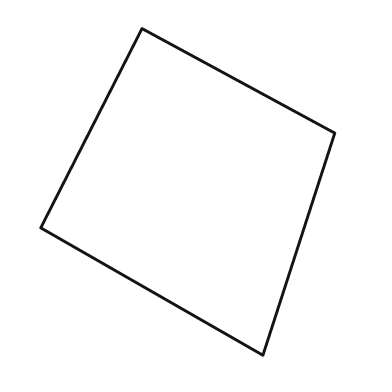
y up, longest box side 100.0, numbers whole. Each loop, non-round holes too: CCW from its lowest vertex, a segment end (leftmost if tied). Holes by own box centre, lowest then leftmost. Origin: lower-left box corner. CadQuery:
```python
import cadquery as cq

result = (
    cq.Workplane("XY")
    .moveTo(68.0, 0.0)
    .lineTo(90.0, 68.0)
    .lineTo(31.0, 100.0)
    .lineTo(0.0, 39.0)
    .close()
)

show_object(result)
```